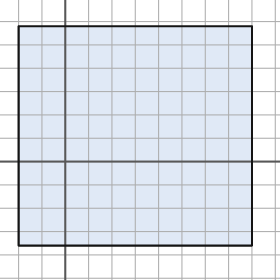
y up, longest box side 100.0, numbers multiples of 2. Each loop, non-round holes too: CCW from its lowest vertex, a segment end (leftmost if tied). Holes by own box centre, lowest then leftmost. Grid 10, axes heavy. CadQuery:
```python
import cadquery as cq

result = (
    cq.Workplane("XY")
    .moveTo(-20.0, -36.0)
    .lineTo(80.0, -36.0)
    .lineTo(80.0, 58.0)
    .lineTo(-20.0, 58.0)
    .close()
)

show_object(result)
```